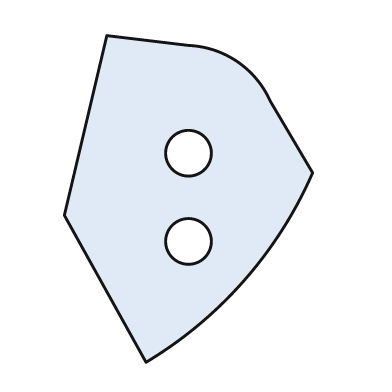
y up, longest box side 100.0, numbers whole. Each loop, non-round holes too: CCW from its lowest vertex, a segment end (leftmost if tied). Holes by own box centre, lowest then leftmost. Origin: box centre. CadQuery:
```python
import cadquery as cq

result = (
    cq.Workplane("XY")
    .moveTo(-13.0, -50.0)
    .threePointArc((17.0, -25.0), (38.0, 8.0))
    .lineTo(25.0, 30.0)
    .threePointArc((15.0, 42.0), (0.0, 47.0))
    .lineTo(-25.0, 50.0)
    .lineTo(-38.0, -5.0)
    .close()
    .moveTo(0.0, -13.0)
    .circle(7.0)
    .moveTo(0.0, 14.0)
    .circle(7.0)
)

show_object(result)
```